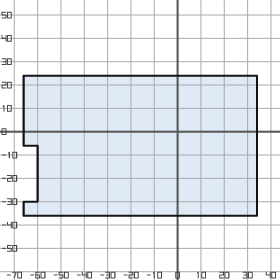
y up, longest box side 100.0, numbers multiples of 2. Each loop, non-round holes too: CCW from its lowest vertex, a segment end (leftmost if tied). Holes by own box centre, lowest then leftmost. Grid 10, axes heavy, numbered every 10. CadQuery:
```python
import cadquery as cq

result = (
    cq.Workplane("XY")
    .moveTo(-66.0, -36.0)
    .lineTo(34.0, -36.0)
    .lineTo(34.0, 24.0)
    .lineTo(-66.0, 24.0)
    .lineTo(-66.0, -6.0)
    .lineTo(-60.0, -6.0)
    .lineTo(-60.0, -30.0)
    .lineTo(-66.0, -30.0)
    .close()
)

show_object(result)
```